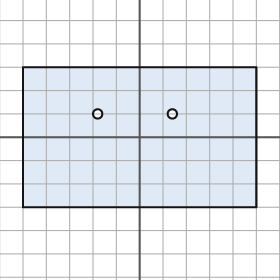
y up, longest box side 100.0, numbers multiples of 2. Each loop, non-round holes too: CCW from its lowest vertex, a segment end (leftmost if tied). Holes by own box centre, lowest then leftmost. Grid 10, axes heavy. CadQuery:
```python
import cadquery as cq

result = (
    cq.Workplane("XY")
    .moveTo(-50.0, -30.0)
    .lineTo(50.0, -30.0)
    .lineTo(50.0, 30.0)
    .lineTo(-50.0, 30.0)
    .close()
    .moveTo(-18.0, 10.0)
    .circle(2.0)
    .moveTo(14.0, 10.0)
    .circle(2.0)
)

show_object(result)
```